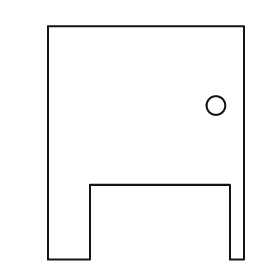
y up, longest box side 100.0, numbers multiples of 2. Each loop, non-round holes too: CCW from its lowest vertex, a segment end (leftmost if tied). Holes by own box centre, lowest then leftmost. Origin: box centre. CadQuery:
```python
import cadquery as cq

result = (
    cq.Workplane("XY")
    .moveTo(-42.0, -50.0)
    .lineTo(-24.0, -50.0)
    .lineTo(-24.0, -18.0)
    .lineTo(36.0, -18.0)
    .lineTo(36.0, -50.0)
    .lineTo(42.0, -50.0)
    .lineTo(42.0, 50.0)
    .lineTo(-42.0, 50.0)
    .close()
    .moveTo(30.0, 16.0)
    .circle(4.0)
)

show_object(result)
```